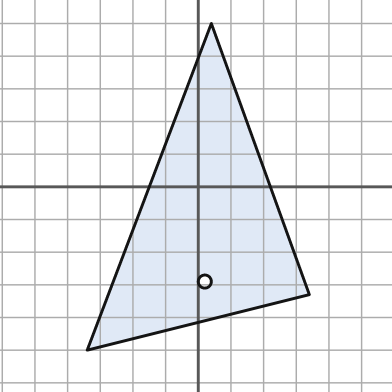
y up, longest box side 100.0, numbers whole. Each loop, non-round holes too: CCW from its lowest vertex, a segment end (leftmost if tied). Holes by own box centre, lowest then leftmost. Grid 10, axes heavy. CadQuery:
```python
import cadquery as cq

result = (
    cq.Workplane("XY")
    .moveTo(-34.0, -50.0)
    .lineTo(34.0, -33.0)
    .lineTo(4.0, 50.0)
    .close()
    .moveTo(2.0, -29.0)
    .circle(2.0)
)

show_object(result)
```